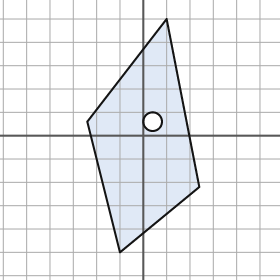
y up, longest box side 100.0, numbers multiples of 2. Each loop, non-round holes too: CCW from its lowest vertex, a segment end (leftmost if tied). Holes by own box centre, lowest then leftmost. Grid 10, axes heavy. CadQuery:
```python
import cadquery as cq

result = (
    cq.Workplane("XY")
    .moveTo(-10.0, -50.0)
    .lineTo(24.0, -22.0)
    .lineTo(10.0, 50.0)
    .lineTo(-24.0, 6.0)
    .close()
    .moveTo(4.0, 6.0)
    .circle(4.0)
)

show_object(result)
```